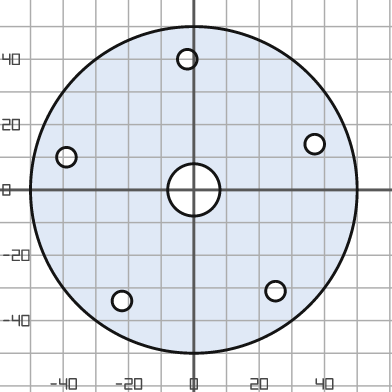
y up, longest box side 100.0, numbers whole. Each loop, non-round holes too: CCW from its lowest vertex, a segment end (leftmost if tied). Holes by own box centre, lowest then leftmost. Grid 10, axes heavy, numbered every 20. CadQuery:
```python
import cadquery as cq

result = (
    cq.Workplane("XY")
    .moveTo(0.0, 0.0)
    .circle(50.0)
    .moveTo(-22.0, -34.0)
    .circle(3.0)
    .moveTo(25.0, -31.0)
    .circle(3.0)
    .moveTo(0.0, 0.0)
    .circle(8.0)
    .moveTo(-39.0, 10.0)
    .circle(3.0)
    .moveTo(37.0, 14.0)
    .circle(3.0)
    .moveTo(-2.0, 40.0)
    .circle(3.0)
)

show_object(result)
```